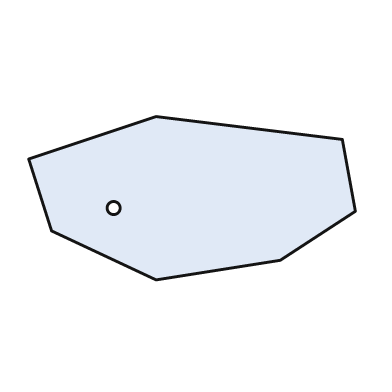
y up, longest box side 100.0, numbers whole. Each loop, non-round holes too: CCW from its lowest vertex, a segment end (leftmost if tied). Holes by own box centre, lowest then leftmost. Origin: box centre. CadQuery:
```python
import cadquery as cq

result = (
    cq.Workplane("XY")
    .moveTo(-11.0, -25.0)
    .lineTo(27.0, -19.0)
    .lineTo(50.0, -4.0)
    .lineTo(46.0, 18.0)
    .lineTo(-11.0, 25.0)
    .lineTo(-50.0, 12.0)
    .lineTo(-43.0, -10.0)
    .close()
    .moveTo(-24.0, -3.0)
    .circle(2.0)
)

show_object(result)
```